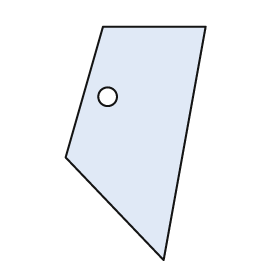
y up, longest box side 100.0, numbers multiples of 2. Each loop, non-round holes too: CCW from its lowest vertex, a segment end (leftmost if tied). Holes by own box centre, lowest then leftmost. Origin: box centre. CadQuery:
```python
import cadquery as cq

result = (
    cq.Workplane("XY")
    .moveTo(12.0, -50.0)
    .lineTo(30.0, 50.0)
    .lineTo(-14.0, 50.0)
    .lineTo(-30.0, -6.0)
    .close()
    .moveTo(-12.0, 20.0)
    .circle(4.0)
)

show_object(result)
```